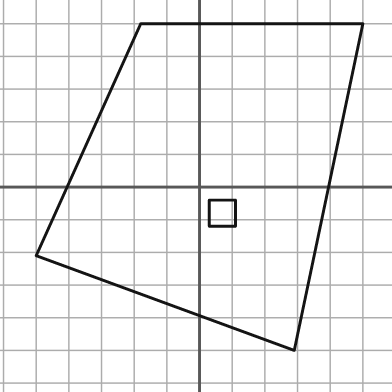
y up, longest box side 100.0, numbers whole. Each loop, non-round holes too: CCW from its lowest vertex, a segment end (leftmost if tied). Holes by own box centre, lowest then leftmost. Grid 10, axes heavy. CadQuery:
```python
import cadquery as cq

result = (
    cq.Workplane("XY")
    .moveTo(29.0, -50.0)
    .lineTo(50.0, 50.0)
    .lineTo(-18.0, 50.0)
    .lineTo(-50.0, -21.0)
    .close()
    .moveTo(3.0, -12.0)
    .lineTo(11.0, -12.0)
    .lineTo(11.0, -4.0)
    .lineTo(3.0, -4.0)
    .close()
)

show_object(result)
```